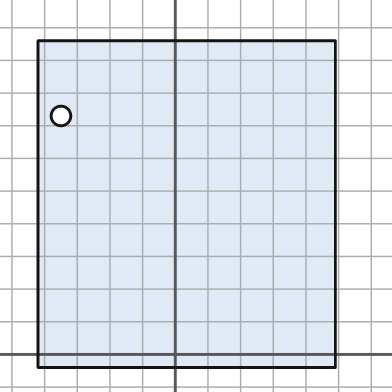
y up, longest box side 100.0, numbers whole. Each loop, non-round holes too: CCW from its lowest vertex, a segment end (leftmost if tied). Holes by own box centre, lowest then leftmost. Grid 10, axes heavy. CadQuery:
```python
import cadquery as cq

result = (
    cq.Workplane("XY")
    .moveTo(-42.0, -4.0)
    .lineTo(49.0, -4.0)
    .lineTo(49.0, 96.0)
    .lineTo(-42.0, 96.0)
    .close()
    .moveTo(-35.0, 73.0)
    .circle(3.0)
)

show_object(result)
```